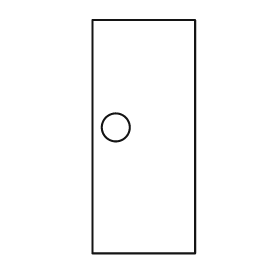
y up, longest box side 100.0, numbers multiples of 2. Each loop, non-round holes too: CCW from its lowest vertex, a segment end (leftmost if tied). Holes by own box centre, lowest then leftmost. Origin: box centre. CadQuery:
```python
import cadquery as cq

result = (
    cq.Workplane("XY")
    .moveTo(-22.0, -50.0)
    .lineTo(22.0, -50.0)
    .lineTo(22.0, 50.0)
    .lineTo(-22.0, 50.0)
    .close()
    .moveTo(-12.0, 4.0)
    .circle(6.0)
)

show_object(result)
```